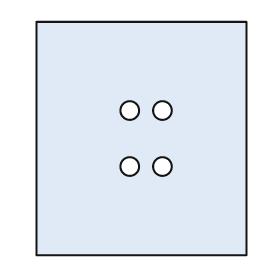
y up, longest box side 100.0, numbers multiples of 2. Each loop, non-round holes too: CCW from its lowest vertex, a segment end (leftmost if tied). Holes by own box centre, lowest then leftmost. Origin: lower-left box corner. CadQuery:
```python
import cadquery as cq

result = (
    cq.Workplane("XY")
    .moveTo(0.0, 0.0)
    .lineTo(90.0, 0.0)
    .lineTo(90.0, 100.0)
    .lineTo(0.0, 100.0)
    .close()
    .moveTo(40.0, 38.0)
    .circle(4.0)
    .moveTo(54.0, 38.0)
    .circle(4.0)
    .moveTo(40.0, 62.0)
    .circle(4.0)
    .moveTo(54.0, 62.0)
    .circle(4.0)
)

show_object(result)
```